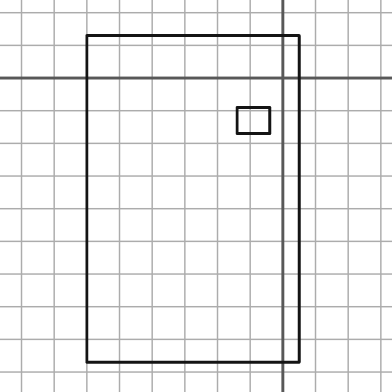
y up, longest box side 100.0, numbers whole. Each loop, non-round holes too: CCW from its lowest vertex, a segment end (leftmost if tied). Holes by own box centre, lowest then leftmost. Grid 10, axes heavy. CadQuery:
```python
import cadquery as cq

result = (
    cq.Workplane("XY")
    .moveTo(-60.0, -87.0)
    .lineTo(5.0, -87.0)
    .lineTo(5.0, 13.0)
    .lineTo(-60.0, 13.0)
    .close()
    .moveTo(-14.0, -17.0)
    .lineTo(-4.0, -17.0)
    .lineTo(-4.0, -9.0)
    .lineTo(-14.0, -9.0)
    .close()
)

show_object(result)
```